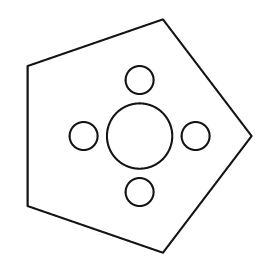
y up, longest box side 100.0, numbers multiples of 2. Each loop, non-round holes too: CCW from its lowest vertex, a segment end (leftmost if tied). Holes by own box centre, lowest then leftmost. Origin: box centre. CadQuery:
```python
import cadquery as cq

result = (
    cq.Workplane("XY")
    .moveTo(10.0, -50.0)
    .lineTo(48.0, 0.0)
    .lineTo(10.0, 50.0)
    .lineTo(-48.0, 30.0)
    .lineTo(-48.0, -30.0)
    .close()
    .moveTo(0.0, -24.0)
    .circle(6.0)
    .moveTo(-24.0, 0.0)
    .circle(6.0)
    .moveTo(0.0, 0.0)
    .circle(14.0)
    .moveTo(24.0, 0.0)
    .circle(6.0)
    .moveTo(0.0, 24.0)
    .circle(6.0)
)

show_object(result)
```